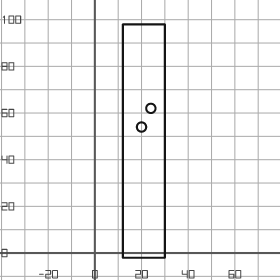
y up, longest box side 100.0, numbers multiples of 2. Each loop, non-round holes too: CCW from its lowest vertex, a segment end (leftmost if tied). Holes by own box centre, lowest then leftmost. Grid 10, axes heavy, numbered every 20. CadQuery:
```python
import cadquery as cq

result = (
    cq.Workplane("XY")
    .moveTo(12.0, -2.0)
    .lineTo(30.0, -2.0)
    .lineTo(30.0, 98.0)
    .lineTo(12.0, 98.0)
    .close()
    .moveTo(20.0, 54.0)
    .circle(2.0)
    .moveTo(24.0, 62.0)
    .circle(2.0)
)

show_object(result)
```